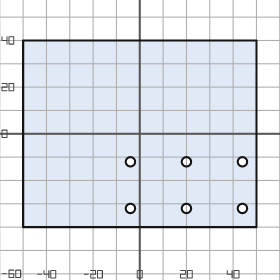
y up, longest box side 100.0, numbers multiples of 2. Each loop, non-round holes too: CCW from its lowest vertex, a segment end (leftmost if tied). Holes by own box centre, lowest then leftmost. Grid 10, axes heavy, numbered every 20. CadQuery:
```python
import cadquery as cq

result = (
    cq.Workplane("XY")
    .moveTo(-50.0, -40.0)
    .lineTo(50.0, -40.0)
    .lineTo(50.0, 40.0)
    .lineTo(-50.0, 40.0)
    .close()
    .moveTo(-4.0, -32.0)
    .circle(2.0)
    .moveTo(20.0, -32.0)
    .circle(2.0)
    .moveTo(44.0, -32.0)
    .circle(2.0)
    .moveTo(-4.0, -12.0)
    .circle(2.0)
    .moveTo(20.0, -12.0)
    .circle(2.0)
    .moveTo(44.0, -12.0)
    .circle(2.0)
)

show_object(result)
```